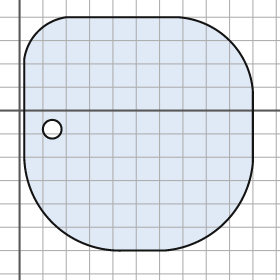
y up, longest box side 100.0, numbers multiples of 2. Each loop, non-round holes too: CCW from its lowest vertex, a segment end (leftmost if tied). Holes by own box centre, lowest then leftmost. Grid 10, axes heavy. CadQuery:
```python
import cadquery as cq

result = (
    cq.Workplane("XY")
    .moveTo(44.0, -60.0)
    .lineTo(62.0, -60.0)
    .threePointArc((88.0, -48.0), (100.0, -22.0))
    .lineTo(100.0, 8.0)
    .threePointArc((90.0, 30.0), (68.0, 40.0))
    .lineTo(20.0, 40.0)
    .threePointArc((8.0, 34.0), (2.0, 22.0))
    .lineTo(2.0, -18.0)
    .threePointArc((14.0, -48.0), (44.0, -60.0))
    .close()
    .moveTo(14.0, -8.0)
    .circle(4.0)
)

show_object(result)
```